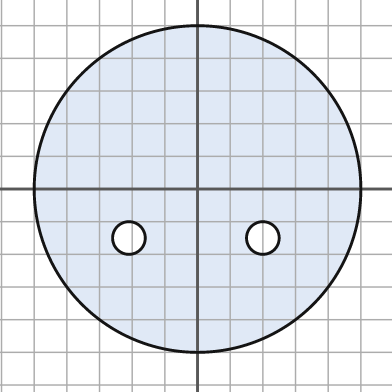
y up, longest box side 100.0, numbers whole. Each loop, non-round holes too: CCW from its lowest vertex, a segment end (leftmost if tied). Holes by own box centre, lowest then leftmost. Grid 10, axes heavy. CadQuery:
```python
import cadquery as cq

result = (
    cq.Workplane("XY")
    .moveTo(0.0, 0.0)
    .circle(50.0)
    .moveTo(-21.0, -15.0)
    .circle(5.0)
    .moveTo(20.0, -15.0)
    .circle(5.0)
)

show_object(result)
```